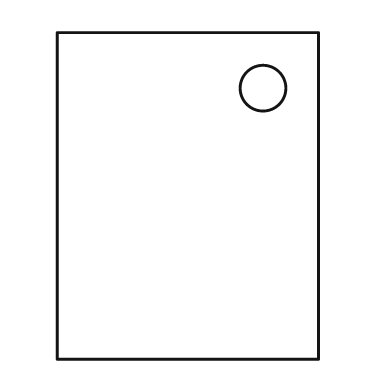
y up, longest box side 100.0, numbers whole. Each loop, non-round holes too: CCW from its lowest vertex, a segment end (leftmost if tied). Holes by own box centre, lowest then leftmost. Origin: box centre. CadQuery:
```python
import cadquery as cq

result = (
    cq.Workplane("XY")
    .moveTo(-40.0, -50.0)
    .lineTo(40.0, -50.0)
    .lineTo(40.0, 50.0)
    .lineTo(-40.0, 50.0)
    .close()
    .moveTo(23.0, 33.0)
    .circle(7.0)
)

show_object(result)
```